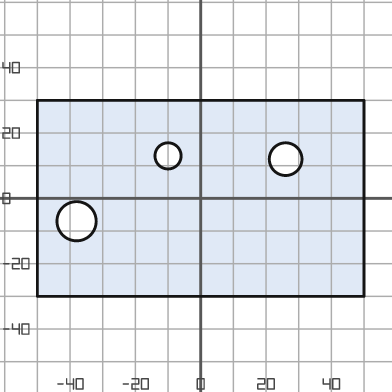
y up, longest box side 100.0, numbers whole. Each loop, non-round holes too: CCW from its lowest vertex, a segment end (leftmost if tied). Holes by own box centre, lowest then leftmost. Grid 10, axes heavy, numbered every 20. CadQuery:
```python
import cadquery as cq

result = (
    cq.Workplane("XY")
    .moveTo(-50.0, -30.0)
    .lineTo(50.0, -30.0)
    .lineTo(50.0, 30.0)
    .lineTo(-50.0, 30.0)
    .close()
    .moveTo(-38.0, -7.0)
    .circle(6.0)
    .moveTo(26.0, 12.0)
    .circle(5.0)
    .moveTo(-10.0, 13.0)
    .circle(4.0)
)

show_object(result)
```